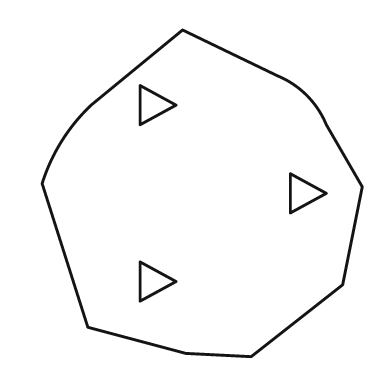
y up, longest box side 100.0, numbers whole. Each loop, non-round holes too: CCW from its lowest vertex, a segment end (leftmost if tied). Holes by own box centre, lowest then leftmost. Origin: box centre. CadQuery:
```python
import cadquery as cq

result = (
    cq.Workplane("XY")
    .moveTo(15.0, -50.0)
    .lineTo(43.0, -28.0)
    .lineTo(49.0, 2.0)
    .lineTo(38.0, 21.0)
    .threePointArc((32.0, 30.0), (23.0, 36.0))
    .lineTo(-6.0, 50.0)
    .lineTo(-34.0, 27.0)
    .threePointArc((-43.0, 16.0), (-49.0, 3.0))
    .lineTo(-35.0, -41.0)
    .lineTo(-5.0, -49.0)
    .close()
    .moveTo(-19.0, -33.0)
    .lineTo(-8.0, -27.0)
    .lineTo(-19.0, -21.0)
    .close()
    .moveTo(27.0, -6.0)
    .lineTo(38.0, 0.0)
    .lineTo(27.0, 6.0)
    .close()
    .moveTo(-19.0, 21.0)
    .lineTo(-8.0, 27.0)
    .lineTo(-19.0, 33.0)
    .close()
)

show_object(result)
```